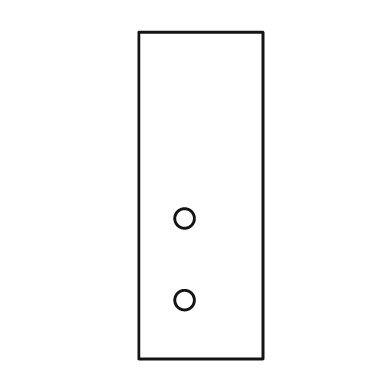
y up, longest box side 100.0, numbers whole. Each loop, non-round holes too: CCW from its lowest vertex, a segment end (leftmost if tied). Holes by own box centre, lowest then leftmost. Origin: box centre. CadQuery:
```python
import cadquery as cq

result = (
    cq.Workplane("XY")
    .moveTo(-19.0, -50.0)
    .lineTo(19.0, -50.0)
    .lineTo(19.0, 50.0)
    .lineTo(-19.0, 50.0)
    .close()
    .moveTo(-5.0, -32.0)
    .circle(3.0)
    .moveTo(-5.0, -7.0)
    .circle(3.0)
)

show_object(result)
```